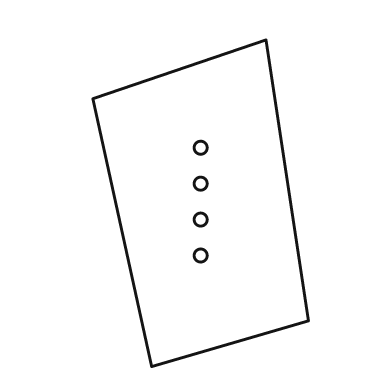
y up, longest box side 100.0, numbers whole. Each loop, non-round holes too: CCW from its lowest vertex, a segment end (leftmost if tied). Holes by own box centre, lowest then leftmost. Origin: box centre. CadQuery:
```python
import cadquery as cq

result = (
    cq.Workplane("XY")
    .moveTo(-15.0, -50.0)
    .lineTo(33.0, -36.0)
    .lineTo(20.0, 50.0)
    .lineTo(-33.0, 32.0)
    .close()
    .moveTo(0.0, -16.0)
    .circle(2.0)
    .moveTo(0.0, -5.0)
    .circle(2.0)
    .moveTo(0.0, 6.0)
    .circle(2.0)
    .moveTo(0.0, 17.0)
    .circle(2.0)
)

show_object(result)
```